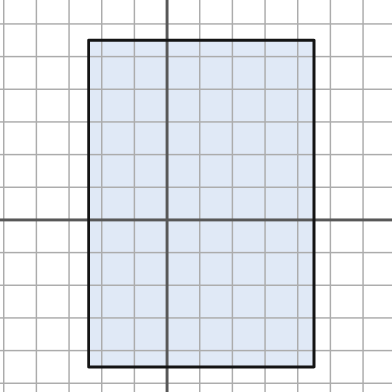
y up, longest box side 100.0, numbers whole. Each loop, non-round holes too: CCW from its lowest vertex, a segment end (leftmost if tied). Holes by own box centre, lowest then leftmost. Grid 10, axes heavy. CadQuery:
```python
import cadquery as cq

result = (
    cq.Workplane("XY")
    .moveTo(-24.0, -45.0)
    .lineTo(45.0, -45.0)
    .lineTo(45.0, 55.0)
    .lineTo(-24.0, 55.0)
    .close()
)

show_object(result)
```